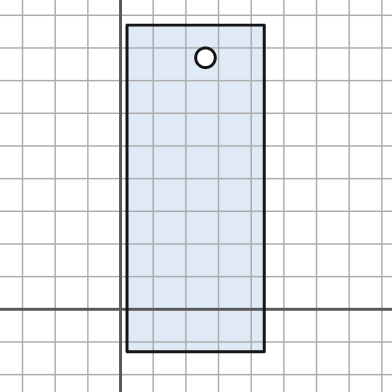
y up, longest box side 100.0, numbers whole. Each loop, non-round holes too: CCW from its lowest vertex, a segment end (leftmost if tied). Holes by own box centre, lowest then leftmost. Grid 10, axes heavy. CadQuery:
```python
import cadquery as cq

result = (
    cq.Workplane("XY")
    .moveTo(2.0, -13.0)
    .lineTo(44.0, -13.0)
    .lineTo(44.0, 87.0)
    .lineTo(2.0, 87.0)
    .close()
    .moveTo(26.0, 77.0)
    .circle(3.0)
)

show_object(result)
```